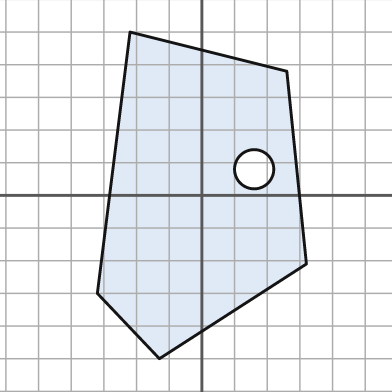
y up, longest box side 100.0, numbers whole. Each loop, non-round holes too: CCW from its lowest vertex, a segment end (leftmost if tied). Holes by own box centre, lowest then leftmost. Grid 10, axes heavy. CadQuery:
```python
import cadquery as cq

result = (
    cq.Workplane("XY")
    .moveTo(-13.0, -50.0)
    .lineTo(32.0, -21.0)
    .lineTo(26.0, 38.0)
    .lineTo(-22.0, 50.0)
    .lineTo(-32.0, -30.0)
    .close()
    .moveTo(16.0, 8.0)
    .circle(6.0)
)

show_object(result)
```